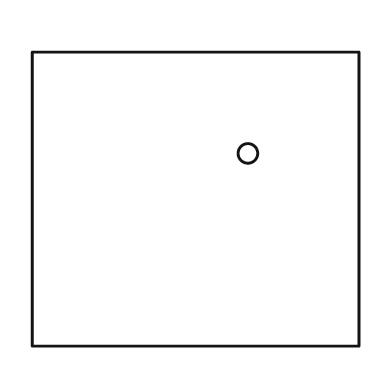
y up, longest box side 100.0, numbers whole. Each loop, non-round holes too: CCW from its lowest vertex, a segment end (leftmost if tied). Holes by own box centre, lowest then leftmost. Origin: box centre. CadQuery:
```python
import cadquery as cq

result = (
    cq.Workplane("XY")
    .moveTo(-50.0, -45.0)
    .lineTo(50.0, -45.0)
    .lineTo(50.0, 45.0)
    .lineTo(-50.0, 45.0)
    .close()
    .moveTo(16.0, 14.0)
    .circle(3.0)
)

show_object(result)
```